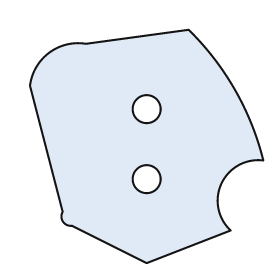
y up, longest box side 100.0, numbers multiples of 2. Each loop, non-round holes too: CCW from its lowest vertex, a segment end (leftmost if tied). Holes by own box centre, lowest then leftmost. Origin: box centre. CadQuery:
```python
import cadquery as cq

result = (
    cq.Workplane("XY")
    .moveTo(0.0, -50.0)
    .lineTo(36.0, -36.0)
    .threePointArc((32.0, -16.0), (50.0, -6.0))
    .threePointArc((38.0, 24.0), (18.0, 50.0))
    .lineTo(-26.0, 44.0)
    .threePointArc((-42.0, 40.0), (-50.0, 26.0))
    .lineTo(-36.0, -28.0)
    .threePointArc((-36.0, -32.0), (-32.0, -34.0))
    .close()
    .moveTo(0.0, -14.0)
    .circle(6.0)
    .moveTo(0.0, 16.0)
    .circle(6.0)
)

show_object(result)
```